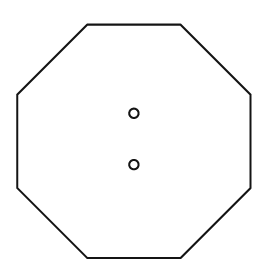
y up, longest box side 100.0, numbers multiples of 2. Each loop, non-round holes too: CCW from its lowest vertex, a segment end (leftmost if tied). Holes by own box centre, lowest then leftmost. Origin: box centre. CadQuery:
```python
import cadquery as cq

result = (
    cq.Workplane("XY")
    .moveTo(-20.0, -50.0)
    .lineTo(20.0, -50.0)
    .lineTo(50.0, -20.0)
    .lineTo(50.0, 20.0)
    .lineTo(20.0, 50.0)
    .lineTo(-20.0, 50.0)
    .lineTo(-50.0, 20.0)
    .lineTo(-50.0, -20.0)
    .close()
    .moveTo(0.0, -10.0)
    .circle(2.0)
    .moveTo(0.0, 12.0)
    .circle(2.0)
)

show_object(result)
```